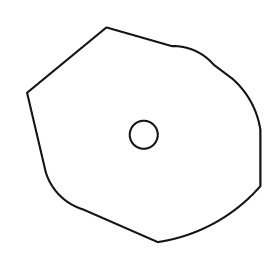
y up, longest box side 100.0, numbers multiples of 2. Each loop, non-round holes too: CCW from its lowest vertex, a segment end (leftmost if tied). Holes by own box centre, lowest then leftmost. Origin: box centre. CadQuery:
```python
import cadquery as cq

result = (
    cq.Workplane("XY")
    .moveTo(6.0, -46.0)
    .threePointArc((30.0, -38.0), (50.0, -22.0))
    .lineTo(50.0, 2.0)
    .threePointArc((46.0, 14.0), (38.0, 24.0))
    .lineTo(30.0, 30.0)
    .threePointArc((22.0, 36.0), (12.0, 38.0))
    .lineTo(-16.0, 46.0)
    .lineTo(-50.0, 18.0)
    .lineTo(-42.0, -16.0)
    .threePointArc((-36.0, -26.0), (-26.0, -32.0))
    .close()
    .moveTo(0.0, 0.0)
    .circle(6.0)
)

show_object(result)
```